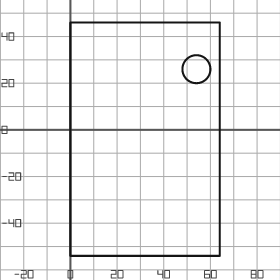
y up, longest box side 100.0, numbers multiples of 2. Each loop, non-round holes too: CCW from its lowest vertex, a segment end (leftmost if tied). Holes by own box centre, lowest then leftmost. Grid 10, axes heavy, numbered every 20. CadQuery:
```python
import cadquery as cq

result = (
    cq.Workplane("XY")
    .moveTo(0.0, -54.0)
    .lineTo(64.0, -54.0)
    .lineTo(64.0, 46.0)
    .lineTo(0.0, 46.0)
    .close()
    .moveTo(54.0, 26.0)
    .circle(6.0)
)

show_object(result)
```